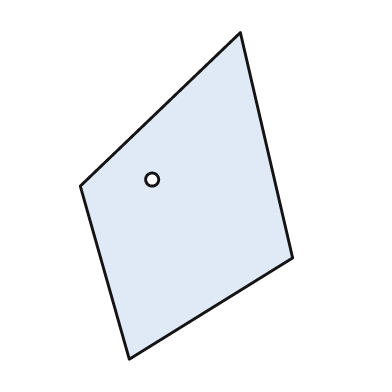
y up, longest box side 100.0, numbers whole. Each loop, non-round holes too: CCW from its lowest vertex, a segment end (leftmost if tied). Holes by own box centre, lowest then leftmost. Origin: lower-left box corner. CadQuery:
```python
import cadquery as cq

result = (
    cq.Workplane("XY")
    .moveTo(15.0, 0.0)
    .lineTo(65.0, 31.0)
    .lineTo(49.0, 100.0)
    .lineTo(0.0, 53.0)
    .close()
    .moveTo(22.0, 55.0)
    .circle(2.0)
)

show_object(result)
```